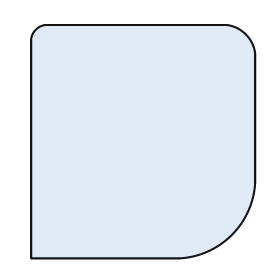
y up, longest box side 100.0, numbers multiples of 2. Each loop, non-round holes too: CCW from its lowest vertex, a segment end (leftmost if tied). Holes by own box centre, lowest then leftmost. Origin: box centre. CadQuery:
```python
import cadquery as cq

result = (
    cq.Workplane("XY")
    .moveTo(-48.0, -50.0)
    .lineTo(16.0, -50.0)
    .threePointArc((38.0, -40.0), (48.0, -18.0))
    .lineTo(48.0, 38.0)
    .threePointArc((44.0, 46.0), (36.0, 50.0))
    .lineTo(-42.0, 50.0)
    .threePointArc((-46.0, 48.0), (-48.0, 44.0))
    .close()
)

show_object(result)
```